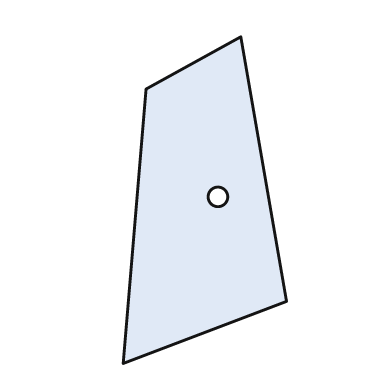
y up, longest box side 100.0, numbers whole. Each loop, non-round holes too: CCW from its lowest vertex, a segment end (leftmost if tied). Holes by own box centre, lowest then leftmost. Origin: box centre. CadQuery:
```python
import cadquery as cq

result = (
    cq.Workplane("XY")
    .moveTo(-25.0, -50.0)
    .lineTo(25.0, -31.0)
    .lineTo(11.0, 50.0)
    .lineTo(-18.0, 34.0)
    .close()
    .moveTo(4.0, 1.0)
    .circle(3.0)
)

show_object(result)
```